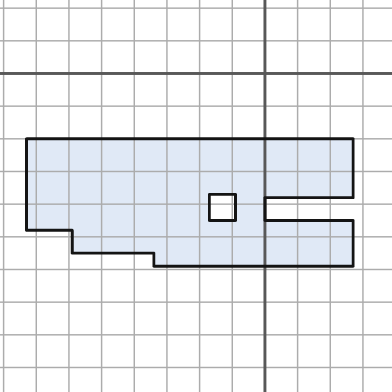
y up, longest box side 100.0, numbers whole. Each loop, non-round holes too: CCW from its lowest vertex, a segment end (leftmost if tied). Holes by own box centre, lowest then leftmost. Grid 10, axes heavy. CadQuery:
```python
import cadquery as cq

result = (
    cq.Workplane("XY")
    .moveTo(-34.0, -59.0)
    .lineTo(27.0, -59.0)
    .lineTo(27.0, -45.0)
    .lineTo(0.0, -45.0)
    .lineTo(0.0, -38.0)
    .lineTo(27.0, -38.0)
    .lineTo(27.0, -20.0)
    .lineTo(-73.0, -20.0)
    .lineTo(-73.0, -48.0)
    .lineTo(-59.0, -48.0)
    .lineTo(-59.0, -55.0)
    .lineTo(-34.0, -55.0)
    .close()
    .moveTo(-17.0, -45.0)
    .lineTo(-9.0, -45.0)
    .lineTo(-9.0, -37.0)
    .lineTo(-17.0, -37.0)
    .close()
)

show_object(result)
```